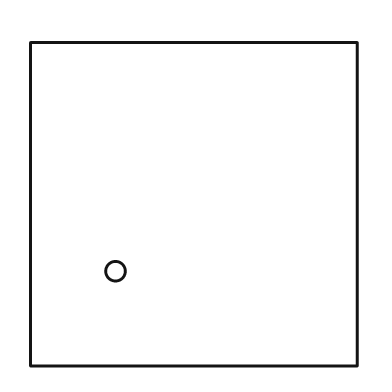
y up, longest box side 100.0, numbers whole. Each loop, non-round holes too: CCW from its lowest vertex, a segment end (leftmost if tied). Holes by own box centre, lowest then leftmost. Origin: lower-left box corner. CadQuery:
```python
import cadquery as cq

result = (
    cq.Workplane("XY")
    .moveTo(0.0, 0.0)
    .lineTo(100.0, 0.0)
    .lineTo(100.0, 99.0)
    .lineTo(0.0, 99.0)
    .close()
    .moveTo(26.0, 29.0)
    .circle(3.0)
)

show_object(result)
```